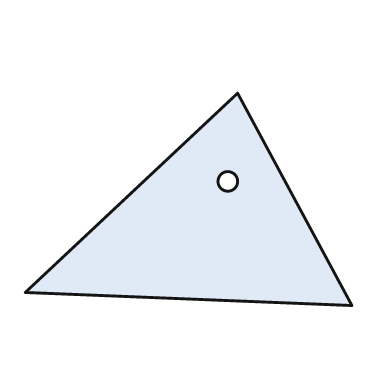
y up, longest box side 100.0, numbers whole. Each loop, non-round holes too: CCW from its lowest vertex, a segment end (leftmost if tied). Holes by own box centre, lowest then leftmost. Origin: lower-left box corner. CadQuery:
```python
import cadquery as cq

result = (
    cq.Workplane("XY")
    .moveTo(100.0, 0.0)
    .lineTo(65.0, 65.0)
    .lineTo(0.0, 4.0)
    .close()
    .moveTo(62.0, 38.0)
    .circle(3.0)
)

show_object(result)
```